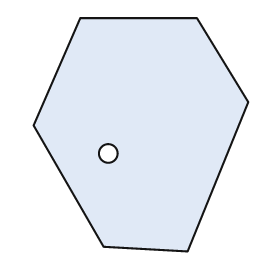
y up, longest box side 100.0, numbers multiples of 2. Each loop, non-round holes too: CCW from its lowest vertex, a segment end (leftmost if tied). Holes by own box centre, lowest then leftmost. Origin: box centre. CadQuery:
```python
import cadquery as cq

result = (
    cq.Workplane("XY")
    .moveTo(20.0, -50.0)
    .lineTo(46.0, 14.0)
    .lineTo(24.0, 50.0)
    .lineTo(-26.0, 50.0)
    .lineTo(-46.0, 4.0)
    .lineTo(-16.0, -48.0)
    .close()
    .moveTo(-14.0, -8.0)
    .circle(4.0)
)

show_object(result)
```